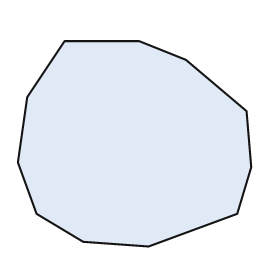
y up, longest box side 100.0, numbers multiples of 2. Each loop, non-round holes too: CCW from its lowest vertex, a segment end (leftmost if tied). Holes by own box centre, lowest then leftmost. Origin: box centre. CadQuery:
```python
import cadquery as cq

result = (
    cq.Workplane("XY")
    .moveTo(6.0, -44.0)
    .lineTo(44.0, -30.0)
    .lineTo(50.0, -10.0)
    .lineTo(48.0, 14.0)
    .lineTo(22.0, 36.0)
    .lineTo(2.0, 44.0)
    .lineTo(-30.0, 44.0)
    .lineTo(-46.0, 20.0)
    .lineTo(-50.0, -8.0)
    .lineTo(-42.0, -30.0)
    .lineTo(-22.0, -42.0)
    .close()
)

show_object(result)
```